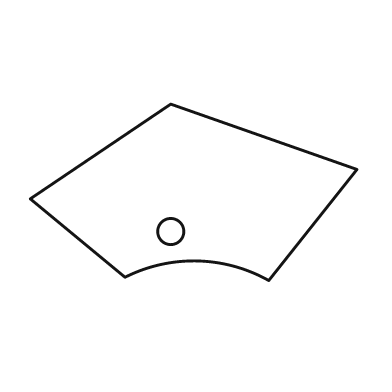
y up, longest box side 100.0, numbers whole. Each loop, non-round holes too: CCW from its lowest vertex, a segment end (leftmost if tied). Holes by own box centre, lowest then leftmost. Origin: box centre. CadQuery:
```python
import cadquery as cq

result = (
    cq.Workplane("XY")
    .moveTo(23.0, -27.0)
    .lineTo(50.0, 7.0)
    .lineTo(-7.0, 27.0)
    .lineTo(-50.0, -2.0)
    .lineTo(-21.0, -26.0)
    .threePointArc((1.0, -21.0), (23.0, -27.0))
    .close()
    .moveTo(-7.0, -12.0)
    .circle(4.0)
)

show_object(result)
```